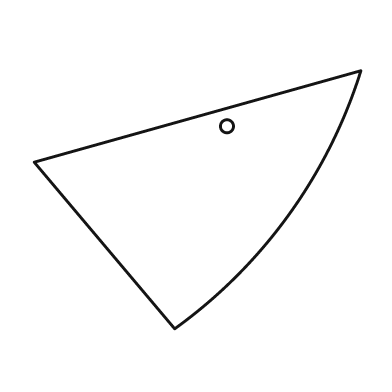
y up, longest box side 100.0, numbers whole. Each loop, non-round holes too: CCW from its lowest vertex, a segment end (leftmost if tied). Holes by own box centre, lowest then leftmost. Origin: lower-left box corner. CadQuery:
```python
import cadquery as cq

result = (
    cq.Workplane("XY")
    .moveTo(43.0, 0.0)
    .threePointArc((78.0, 35.0), (100.0, 79.0))
    .lineTo(0.0, 51.0)
    .close()
    .moveTo(59.0, 62.0)
    .circle(2.0)
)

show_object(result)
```